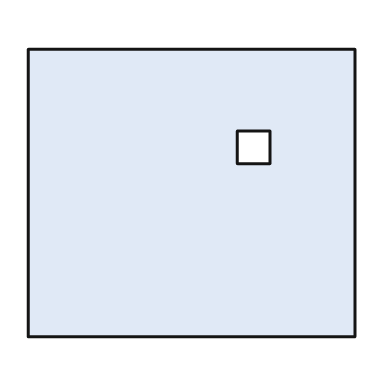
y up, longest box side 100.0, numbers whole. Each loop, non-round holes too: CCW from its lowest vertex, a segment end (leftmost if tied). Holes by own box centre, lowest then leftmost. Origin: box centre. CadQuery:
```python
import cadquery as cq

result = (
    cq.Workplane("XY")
    .moveTo(-50.0, -44.0)
    .lineTo(50.0, -44.0)
    .lineTo(50.0, 44.0)
    .lineTo(-50.0, 44.0)
    .close()
    .moveTo(14.0, 9.0)
    .lineTo(24.0, 9.0)
    .lineTo(24.0, 19.0)
    .lineTo(14.0, 19.0)
    .close()
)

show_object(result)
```